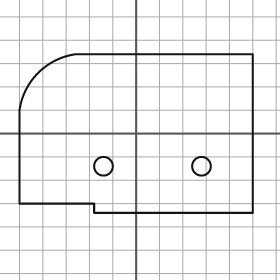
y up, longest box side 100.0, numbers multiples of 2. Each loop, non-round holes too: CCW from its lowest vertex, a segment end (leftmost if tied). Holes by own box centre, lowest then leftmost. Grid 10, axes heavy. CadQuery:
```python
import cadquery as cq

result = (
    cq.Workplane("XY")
    .moveTo(-18.0, -34.0)
    .lineTo(50.0, -34.0)
    .lineTo(50.0, 34.0)
    .lineTo(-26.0, 34.0)
    .threePointArc((-42.0, 26.0), (-50.0, 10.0))
    .lineTo(-50.0, -30.0)
    .lineTo(-18.0, -30.0)
    .close()
    .moveTo(-14.0, -14.0)
    .circle(4.0)
    .moveTo(28.0, -14.0)
    .circle(4.0)
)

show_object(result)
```